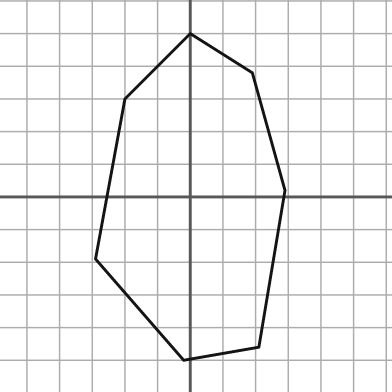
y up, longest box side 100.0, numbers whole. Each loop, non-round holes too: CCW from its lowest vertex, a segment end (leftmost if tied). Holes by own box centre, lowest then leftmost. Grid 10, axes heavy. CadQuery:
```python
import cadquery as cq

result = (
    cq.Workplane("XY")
    .moveTo(-2.0, -50.0)
    .lineTo(21.0, -46.0)
    .lineTo(29.0, 2.0)
    .lineTo(19.0, 38.0)
    .lineTo(0.0, 50.0)
    .lineTo(-20.0, 30.0)
    .lineTo(-29.0, -19.0)
    .close()
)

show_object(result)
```